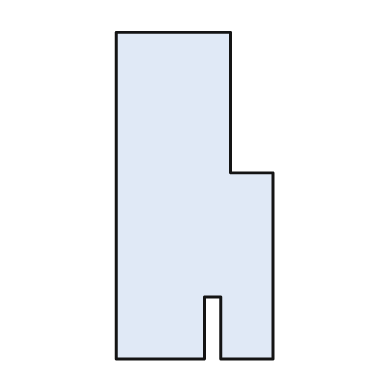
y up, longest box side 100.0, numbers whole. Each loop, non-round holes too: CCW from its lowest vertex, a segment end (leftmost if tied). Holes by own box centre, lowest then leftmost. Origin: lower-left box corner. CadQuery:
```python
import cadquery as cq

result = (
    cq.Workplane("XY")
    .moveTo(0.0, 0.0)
    .lineTo(27.0, 0.0)
    .lineTo(27.0, 19.0)
    .lineTo(32.0, 19.0)
    .lineTo(32.0, 0.0)
    .lineTo(48.0, 0.0)
    .lineTo(48.0, 57.0)
    .lineTo(35.0, 57.0)
    .lineTo(35.0, 100.0)
    .lineTo(0.0, 100.0)
    .close()
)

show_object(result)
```